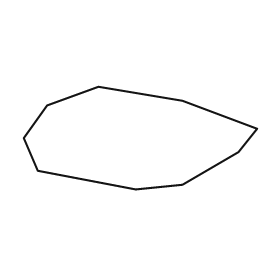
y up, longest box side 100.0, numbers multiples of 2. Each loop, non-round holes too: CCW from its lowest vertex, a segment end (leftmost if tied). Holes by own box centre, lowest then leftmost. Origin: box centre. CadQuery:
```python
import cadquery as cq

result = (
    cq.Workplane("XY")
    .moveTo(-2.0, -22.0)
    .lineTo(18.0, -20.0)
    .lineTo(42.0, -6.0)
    .lineTo(50.0, 4.0)
    .lineTo(18.0, 16.0)
    .lineTo(-18.0, 22.0)
    .lineTo(-40.0, 14.0)
    .lineTo(-50.0, 0.0)
    .lineTo(-44.0, -14.0)
    .close()
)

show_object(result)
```